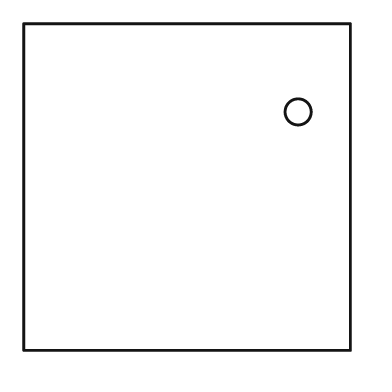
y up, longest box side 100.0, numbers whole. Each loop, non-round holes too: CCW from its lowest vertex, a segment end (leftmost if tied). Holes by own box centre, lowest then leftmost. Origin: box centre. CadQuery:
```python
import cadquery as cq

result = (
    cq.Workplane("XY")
    .moveTo(-50.0, -50.0)
    .lineTo(50.0, -50.0)
    .lineTo(50.0, 50.0)
    .lineTo(-50.0, 50.0)
    .close()
    .moveTo(34.0, 23.0)
    .circle(4.0)
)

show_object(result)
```